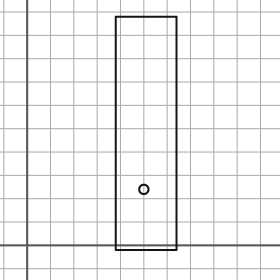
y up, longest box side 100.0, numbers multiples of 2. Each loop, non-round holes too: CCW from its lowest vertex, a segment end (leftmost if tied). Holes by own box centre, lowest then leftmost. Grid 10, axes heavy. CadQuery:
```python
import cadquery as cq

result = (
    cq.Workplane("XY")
    .moveTo(38.0, -2.0)
    .lineTo(64.0, -2.0)
    .lineTo(64.0, 98.0)
    .lineTo(38.0, 98.0)
    .close()
    .moveTo(50.0, 24.0)
    .circle(2.0)
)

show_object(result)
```